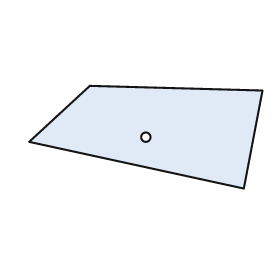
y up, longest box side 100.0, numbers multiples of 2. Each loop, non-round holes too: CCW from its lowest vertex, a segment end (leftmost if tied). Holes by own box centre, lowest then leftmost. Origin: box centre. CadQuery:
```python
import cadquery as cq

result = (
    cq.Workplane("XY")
    .moveTo(42.0, -22.0)
    .lineTo(50.0, 20.0)
    .lineTo(-24.0, 22.0)
    .lineTo(-50.0, -2.0)
    .close()
    .moveTo(0.0, 0.0)
    .circle(2.0)
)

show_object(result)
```